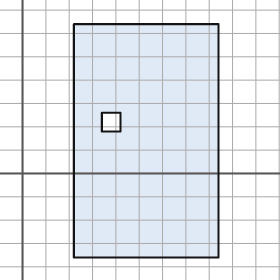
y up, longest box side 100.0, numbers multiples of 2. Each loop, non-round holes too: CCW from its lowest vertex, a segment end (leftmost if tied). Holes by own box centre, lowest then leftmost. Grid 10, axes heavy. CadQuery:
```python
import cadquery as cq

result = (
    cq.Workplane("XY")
    .moveTo(22.0, -36.0)
    .lineTo(84.0, -36.0)
    .lineTo(84.0, 64.0)
    .lineTo(22.0, 64.0)
    .close()
    .moveTo(34.0, 18.0)
    .lineTo(42.0, 18.0)
    .lineTo(42.0, 26.0)
    .lineTo(34.0, 26.0)
    .close()
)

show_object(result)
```